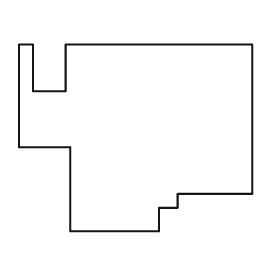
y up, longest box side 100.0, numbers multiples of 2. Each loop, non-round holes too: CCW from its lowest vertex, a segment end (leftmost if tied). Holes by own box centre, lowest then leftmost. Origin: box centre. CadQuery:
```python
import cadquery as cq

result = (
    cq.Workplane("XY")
    .moveTo(-28.0, -40.0)
    .lineTo(10.0, -40.0)
    .lineTo(10.0, -30.0)
    .lineTo(18.0, -30.0)
    .lineTo(18.0, -24.0)
    .lineTo(50.0, -24.0)
    .lineTo(50.0, 40.0)
    .lineTo(-30.0, 40.0)
    .lineTo(-30.0, 20.0)
    .lineTo(-44.0, 20.0)
    .lineTo(-44.0, 40.0)
    .lineTo(-50.0, 40.0)
    .lineTo(-50.0, -4.0)
    .lineTo(-28.0, -4.0)
    .close()
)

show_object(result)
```